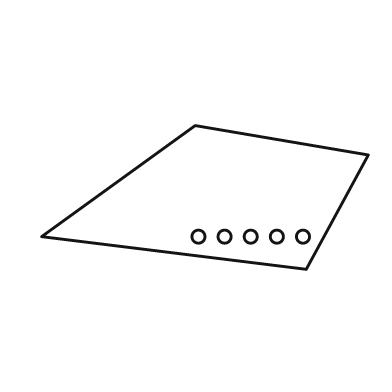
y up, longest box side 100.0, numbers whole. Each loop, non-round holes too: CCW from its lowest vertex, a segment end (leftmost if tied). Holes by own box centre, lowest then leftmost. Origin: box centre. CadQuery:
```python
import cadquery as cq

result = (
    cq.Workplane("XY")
    .moveTo(31.0, -22.0)
    .lineTo(50.0, 13.0)
    .lineTo(-3.0, 22.0)
    .lineTo(-50.0, -12.0)
    .close()
    .moveTo(-2.0, -12.0)
    .circle(2.0)
    .moveTo(6.0, -12.0)
    .circle(2.0)
    .moveTo(14.0, -12.0)
    .circle(2.0)
    .moveTo(22.0, -12.0)
    .circle(2.0)
    .moveTo(30.0, -12.0)
    .circle(2.0)
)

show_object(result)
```